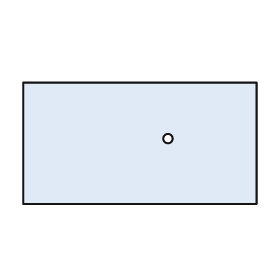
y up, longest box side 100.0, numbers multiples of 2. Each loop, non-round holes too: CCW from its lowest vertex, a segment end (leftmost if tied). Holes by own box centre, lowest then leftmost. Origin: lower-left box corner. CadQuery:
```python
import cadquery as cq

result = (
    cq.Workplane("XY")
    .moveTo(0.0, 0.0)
    .lineTo(100.0, 0.0)
    .lineTo(100.0, 52.0)
    .lineTo(0.0, 52.0)
    .close()
    .moveTo(62.0, 28.0)
    .circle(2.0)
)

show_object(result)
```